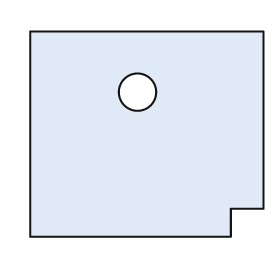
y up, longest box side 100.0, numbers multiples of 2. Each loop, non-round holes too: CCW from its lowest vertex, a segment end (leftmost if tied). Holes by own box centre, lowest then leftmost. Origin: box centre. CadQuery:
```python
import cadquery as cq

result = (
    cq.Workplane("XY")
    .moveTo(-50.0, -44.0)
    .lineTo(36.0, -44.0)
    .lineTo(36.0, -32.0)
    .lineTo(50.0, -32.0)
    .lineTo(50.0, 44.0)
    .lineTo(-50.0, 44.0)
    .close()
    .moveTo(-4.0, 18.0)
    .circle(8.0)
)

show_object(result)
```